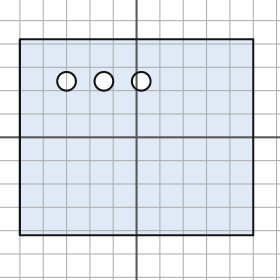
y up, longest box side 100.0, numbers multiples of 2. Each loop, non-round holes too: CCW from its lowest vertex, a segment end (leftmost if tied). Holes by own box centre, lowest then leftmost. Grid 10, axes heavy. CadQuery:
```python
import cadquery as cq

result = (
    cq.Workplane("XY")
    .moveTo(-50.0, -42.0)
    .lineTo(50.0, -42.0)
    .lineTo(50.0, 42.0)
    .lineTo(-50.0, 42.0)
    .close()
    .moveTo(-30.0, 24.0)
    .circle(4.0)
    .moveTo(-14.0, 24.0)
    .circle(4.0)
    .moveTo(2.0, 24.0)
    .circle(4.0)
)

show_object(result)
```